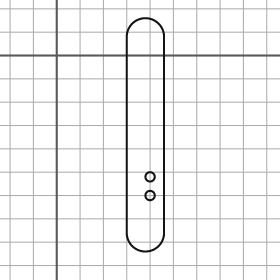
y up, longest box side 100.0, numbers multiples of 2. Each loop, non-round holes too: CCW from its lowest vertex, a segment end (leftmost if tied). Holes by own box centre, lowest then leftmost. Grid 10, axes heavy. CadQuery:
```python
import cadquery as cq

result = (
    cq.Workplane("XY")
    .moveTo(30.0, -76.0)
    .threePointArc((38.0, -84.0), (46.0, -76.0))
    .lineTo(46.0, 8.0)
    .threePointArc((38.0, 16.0), (30.0, 8.0))
    .close()
    .moveTo(40.0, -60.0)
    .circle(2.0)
    .moveTo(40.0, -52.0)
    .circle(2.0)
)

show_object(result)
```